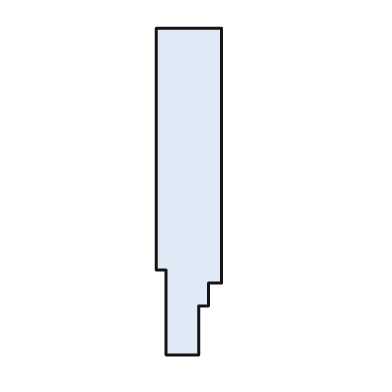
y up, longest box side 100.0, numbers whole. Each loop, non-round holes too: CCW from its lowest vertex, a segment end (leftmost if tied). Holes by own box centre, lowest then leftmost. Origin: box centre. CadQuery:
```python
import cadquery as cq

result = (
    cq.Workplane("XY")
    .moveTo(-7.0, -50.0)
    .lineTo(3.0, -50.0)
    .lineTo(3.0, -35.0)
    .lineTo(6.0, -35.0)
    .lineTo(6.0, -28.0)
    .lineTo(10.0, -28.0)
    .lineTo(10.0, 50.0)
    .lineTo(-10.0, 50.0)
    .lineTo(-10.0, -24.0)
    .lineTo(-7.0, -24.0)
    .close()
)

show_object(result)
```